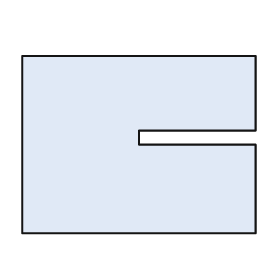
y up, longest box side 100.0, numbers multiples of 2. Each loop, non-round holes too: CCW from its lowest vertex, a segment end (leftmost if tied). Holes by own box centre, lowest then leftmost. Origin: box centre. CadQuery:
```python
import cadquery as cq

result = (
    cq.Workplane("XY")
    .moveTo(-50.0, -38.0)
    .lineTo(50.0, -38.0)
    .lineTo(50.0, 0.0)
    .lineTo(0.0, 0.0)
    .lineTo(0.0, 6.0)
    .lineTo(50.0, 6.0)
    .lineTo(50.0, 38.0)
    .lineTo(-50.0, 38.0)
    .close()
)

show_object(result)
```